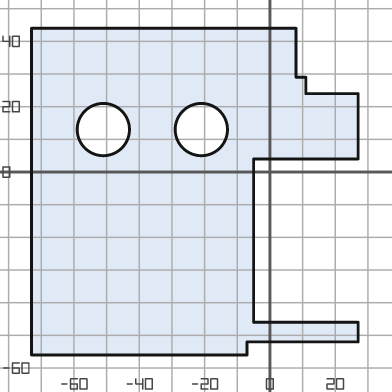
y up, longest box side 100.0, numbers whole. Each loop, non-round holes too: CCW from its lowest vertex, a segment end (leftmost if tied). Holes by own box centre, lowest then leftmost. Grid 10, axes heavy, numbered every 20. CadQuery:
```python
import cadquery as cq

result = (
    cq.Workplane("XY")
    .moveTo(-73.0, -56.0)
    .lineTo(-7.0, -56.0)
    .lineTo(-7.0, -52.0)
    .lineTo(27.0, -52.0)
    .lineTo(27.0, -46.0)
    .lineTo(-5.0, -46.0)
    .lineTo(-5.0, 4.0)
    .lineTo(27.0, 4.0)
    .lineTo(27.0, 24.0)
    .lineTo(11.0, 24.0)
    .lineTo(11.0, 29.0)
    .lineTo(8.0, 29.0)
    .lineTo(8.0, 44.0)
    .lineTo(-73.0, 44.0)
    .close()
    .moveTo(-51.0, 13.0)
    .circle(8.0)
    .moveTo(-21.0, 13.0)
    .circle(8.0)
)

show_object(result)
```